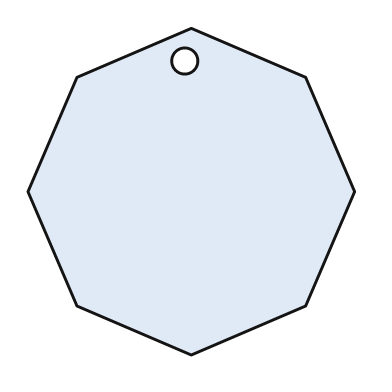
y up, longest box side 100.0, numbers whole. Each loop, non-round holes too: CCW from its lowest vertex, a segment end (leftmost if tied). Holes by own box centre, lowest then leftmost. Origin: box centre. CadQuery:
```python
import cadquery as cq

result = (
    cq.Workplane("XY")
    .moveTo(0.0, -50.0)
    .lineTo(35.0, -35.0)
    .lineTo(50.0, 0.0)
    .lineTo(35.0, 35.0)
    .lineTo(0.0, 50.0)
    .lineTo(-35.0, 35.0)
    .lineTo(-50.0, 0.0)
    .lineTo(-35.0, -35.0)
    .close()
    .moveTo(-2.0, 40.0)
    .circle(4.0)
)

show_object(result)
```